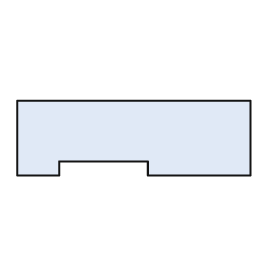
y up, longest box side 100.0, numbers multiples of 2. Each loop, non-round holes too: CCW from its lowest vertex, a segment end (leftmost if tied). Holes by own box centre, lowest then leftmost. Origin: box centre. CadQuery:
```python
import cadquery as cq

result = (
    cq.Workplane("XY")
    .moveTo(-50.0, -16.0)
    .lineTo(-32.0, -16.0)
    .lineTo(-32.0, -10.0)
    .lineTo(6.0, -10.0)
    .lineTo(6.0, -16.0)
    .lineTo(50.0, -16.0)
    .lineTo(50.0, 16.0)
    .lineTo(-50.0, 16.0)
    .close()
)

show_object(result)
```